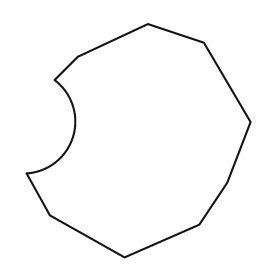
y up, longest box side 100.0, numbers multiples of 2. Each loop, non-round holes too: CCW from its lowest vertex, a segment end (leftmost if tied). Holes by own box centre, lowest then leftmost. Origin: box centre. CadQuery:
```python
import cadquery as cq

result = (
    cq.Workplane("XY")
    .moveTo(-6.0, -50.0)
    .lineTo(26.0, -36.0)
    .lineTo(38.0, -18.0)
    .lineTo(48.0, 8.0)
    .lineTo(28.0, 42.0)
    .lineTo(4.0, 50.0)
    .lineTo(-26.0, 36.0)
    .lineTo(-36.0, 26.0)
    .threePointArc((-28.0, 2.0), (-48.0, -14.0))
    .lineTo(-38.0, -32.0)
    .close()
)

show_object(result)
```